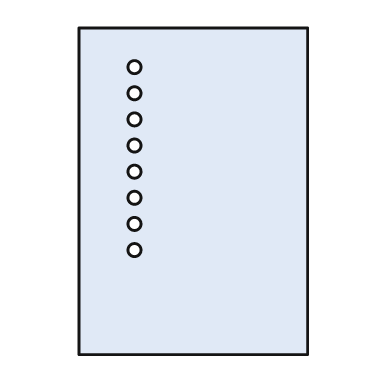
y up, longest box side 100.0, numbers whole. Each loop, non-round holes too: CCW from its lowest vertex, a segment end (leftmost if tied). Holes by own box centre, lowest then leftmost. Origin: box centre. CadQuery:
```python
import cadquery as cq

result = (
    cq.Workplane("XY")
    .moveTo(-35.0, -50.0)
    .lineTo(35.0, -50.0)
    .lineTo(35.0, 50.0)
    .lineTo(-35.0, 50.0)
    .close()
    .moveTo(-18.0, -18.0)
    .circle(2.0)
    .moveTo(-18.0, -10.0)
    .circle(2.0)
    .moveTo(-18.0, -2.0)
    .circle(2.0)
    .moveTo(-18.0, 6.0)
    .circle(2.0)
    .moveTo(-18.0, 14.0)
    .circle(2.0)
    .moveTo(-18.0, 22.0)
    .circle(2.0)
    .moveTo(-18.0, 30.0)
    .circle(2.0)
    .moveTo(-18.0, 38.0)
    .circle(2.0)
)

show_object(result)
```